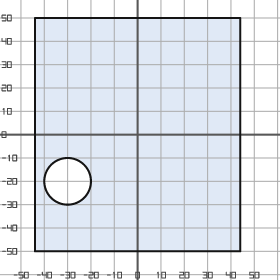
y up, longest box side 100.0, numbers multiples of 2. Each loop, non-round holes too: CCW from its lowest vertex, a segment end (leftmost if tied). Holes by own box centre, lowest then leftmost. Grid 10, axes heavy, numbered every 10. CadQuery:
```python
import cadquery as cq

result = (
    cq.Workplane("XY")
    .moveTo(-44.0, -50.0)
    .lineTo(44.0, -50.0)
    .lineTo(44.0, 50.0)
    .lineTo(-44.0, 50.0)
    .close()
    .moveTo(-30.0, -20.0)
    .circle(10.0)
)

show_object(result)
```